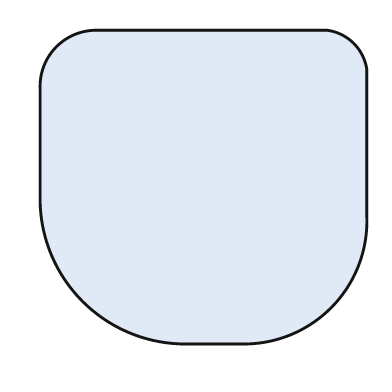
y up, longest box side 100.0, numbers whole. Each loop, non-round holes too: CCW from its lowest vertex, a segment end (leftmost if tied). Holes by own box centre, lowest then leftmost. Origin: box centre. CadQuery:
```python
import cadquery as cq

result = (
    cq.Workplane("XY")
    .moveTo(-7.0, -48.0)
    .lineTo(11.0, -48.0)
    .threePointArc((39.0, -37.0), (50.0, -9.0))
    .lineTo(50.0, 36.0)
    .threePointArc((46.0, 44.0), (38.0, 48.0))
    .lineTo(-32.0, 48.0)
    .threePointArc((-45.0, 43.0), (-50.0, 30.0))
    .lineTo(-50.0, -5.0)
    .threePointArc((-37.0, -35.0), (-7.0, -48.0))
    .close()
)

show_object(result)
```